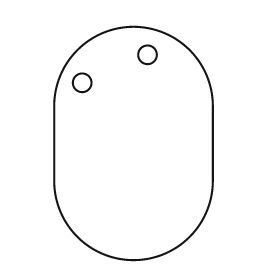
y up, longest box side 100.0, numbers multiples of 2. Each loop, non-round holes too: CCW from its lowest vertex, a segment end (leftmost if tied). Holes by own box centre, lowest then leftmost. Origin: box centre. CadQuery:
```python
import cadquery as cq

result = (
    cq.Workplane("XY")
    .moveTo(-34.0, -16.0)
    .threePointArc((0.0, -50.0), (34.0, -16.0))
    .lineTo(34.0, 16.0)
    .threePointArc((0.0, 50.0), (-34.0, 16.0))
    .close()
    .moveTo(-22.0, 26.0)
    .circle(4.0)
    .moveTo(6.0, 38.0)
    .circle(4.0)
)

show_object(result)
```